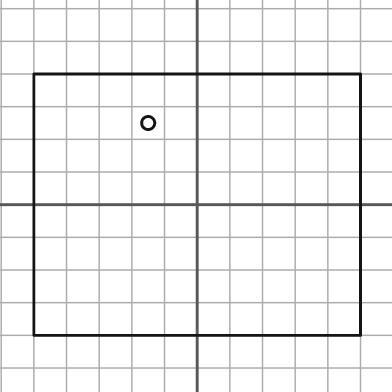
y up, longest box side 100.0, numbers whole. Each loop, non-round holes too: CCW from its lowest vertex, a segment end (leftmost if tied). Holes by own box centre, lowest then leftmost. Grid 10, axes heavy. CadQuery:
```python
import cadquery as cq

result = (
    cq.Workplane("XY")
    .moveTo(-50.0, -40.0)
    .lineTo(50.0, -40.0)
    .lineTo(50.0, 40.0)
    .lineTo(-50.0, 40.0)
    .close()
    .moveTo(-15.0, 25.0)
    .circle(2.0)
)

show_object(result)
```